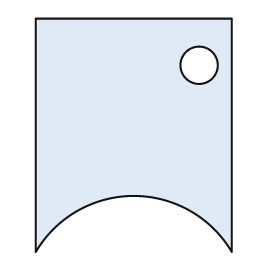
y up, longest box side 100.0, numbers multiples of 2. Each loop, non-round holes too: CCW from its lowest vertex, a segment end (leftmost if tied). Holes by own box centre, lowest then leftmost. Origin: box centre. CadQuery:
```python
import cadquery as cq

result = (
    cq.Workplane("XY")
    .moveTo(-42.0, -50.0)
    .threePointArc((0.0, -26.0), (42.0, -50.0))
    .lineTo(42.0, 50.0)
    .lineTo(-42.0, 50.0)
    .close()
    .moveTo(28.0, 30.0)
    .circle(8.0)
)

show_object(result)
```